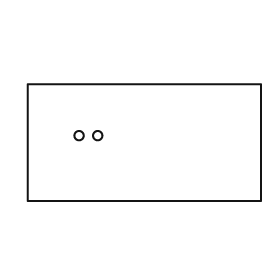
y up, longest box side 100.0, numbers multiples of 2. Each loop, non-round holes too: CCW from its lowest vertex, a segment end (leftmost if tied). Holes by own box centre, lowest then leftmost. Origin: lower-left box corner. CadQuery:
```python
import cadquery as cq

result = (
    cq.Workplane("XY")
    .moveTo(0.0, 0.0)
    .lineTo(100.0, 0.0)
    .lineTo(100.0, 50.0)
    .lineTo(0.0, 50.0)
    .close()
    .moveTo(22.0, 28.0)
    .circle(2.0)
    .moveTo(30.0, 28.0)
    .circle(2.0)
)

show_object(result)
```